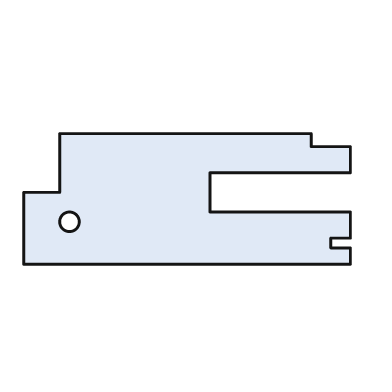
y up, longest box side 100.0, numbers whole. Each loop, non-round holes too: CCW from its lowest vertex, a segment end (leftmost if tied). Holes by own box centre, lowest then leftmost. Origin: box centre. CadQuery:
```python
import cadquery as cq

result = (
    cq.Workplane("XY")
    .moveTo(-50.0, -20.0)
    .lineTo(50.0, -20.0)
    .lineTo(50.0, -15.0)
    .lineTo(44.0, -15.0)
    .lineTo(44.0, -12.0)
    .lineTo(50.0, -12.0)
    .lineTo(50.0, -4.0)
    .lineTo(7.0, -4.0)
    .lineTo(7.0, 8.0)
    .lineTo(50.0, 8.0)
    .lineTo(50.0, 16.0)
    .lineTo(38.0, 16.0)
    .lineTo(38.0, 20.0)
    .lineTo(-39.0, 20.0)
    .lineTo(-39.0, 2.0)
    .lineTo(-50.0, 2.0)
    .close()
    .moveTo(-36.0, -7.0)
    .circle(3.0)
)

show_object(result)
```